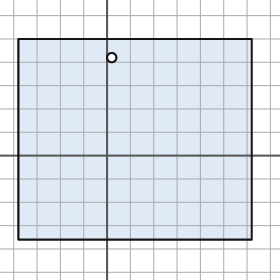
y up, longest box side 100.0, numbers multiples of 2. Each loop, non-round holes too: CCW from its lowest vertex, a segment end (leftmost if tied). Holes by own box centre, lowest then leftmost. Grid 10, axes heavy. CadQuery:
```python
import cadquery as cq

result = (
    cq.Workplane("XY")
    .moveTo(-38.0, -36.0)
    .lineTo(62.0, -36.0)
    .lineTo(62.0, 50.0)
    .lineTo(-38.0, 50.0)
    .close()
    .moveTo(2.0, 42.0)
    .circle(2.0)
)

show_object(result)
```